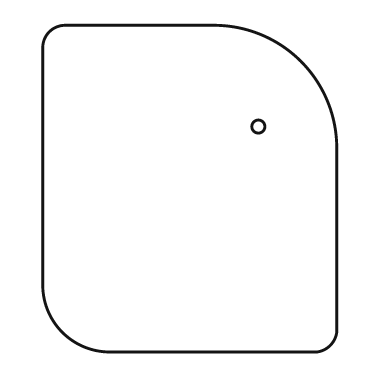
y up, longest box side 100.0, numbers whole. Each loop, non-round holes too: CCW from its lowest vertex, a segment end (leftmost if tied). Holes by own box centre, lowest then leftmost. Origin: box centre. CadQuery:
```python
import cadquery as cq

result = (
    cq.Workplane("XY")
    .moveTo(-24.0, -50.0)
    .lineTo(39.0, -50.0)
    .threePointArc((43.0, -48.0), (45.0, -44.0))
    .lineTo(45.0, 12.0)
    .threePointArc((34.0, 39.0), (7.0, 50.0))
    .lineTo(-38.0, 50.0)
    .threePointArc((-43.0, 48.0), (-45.0, 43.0))
    .lineTo(-45.0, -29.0)
    .threePointArc((-39.0, -44.0), (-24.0, -50.0))
    .close()
    .moveTo(21.0, 19.0)
    .circle(2.0)
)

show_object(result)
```